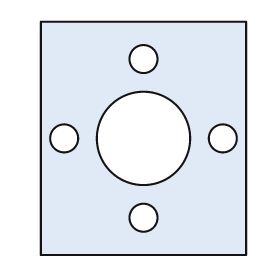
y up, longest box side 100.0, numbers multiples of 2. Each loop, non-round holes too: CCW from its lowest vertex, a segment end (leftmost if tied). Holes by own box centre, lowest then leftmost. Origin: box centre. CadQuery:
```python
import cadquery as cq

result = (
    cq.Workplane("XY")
    .moveTo(-44.0, -50.0)
    .lineTo(44.0, -50.0)
    .lineTo(44.0, 50.0)
    .lineTo(-44.0, 50.0)
    .close()
    .moveTo(0.0, -34.0)
    .circle(6.0)
    .moveTo(-34.0, 0.0)
    .circle(6.0)
    .moveTo(0.0, 0.0)
    .circle(20.0)
    .moveTo(34.0, 0.0)
    .circle(6.0)
    .moveTo(0.0, 34.0)
    .circle(6.0)
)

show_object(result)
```